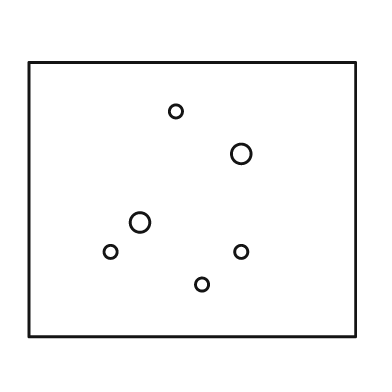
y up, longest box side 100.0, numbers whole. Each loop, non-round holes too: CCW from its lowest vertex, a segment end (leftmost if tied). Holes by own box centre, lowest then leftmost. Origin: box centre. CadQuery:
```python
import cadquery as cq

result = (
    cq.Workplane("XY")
    .moveTo(-50.0, -42.0)
    .lineTo(50.0, -42.0)
    .lineTo(50.0, 42.0)
    .lineTo(-50.0, 42.0)
    .close()
    .moveTo(3.0, -26.0)
    .circle(2.0)
    .moveTo(-25.0, -16.0)
    .circle(2.0)
    .moveTo(15.0, -16.0)
    .circle(2.0)
    .moveTo(-16.0, -7.0)
    .circle(3.0)
    .moveTo(15.0, 14.0)
    .circle(3.0)
    .moveTo(-5.0, 27.0)
    .circle(2.0)
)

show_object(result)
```